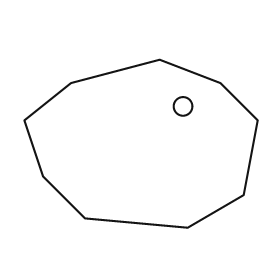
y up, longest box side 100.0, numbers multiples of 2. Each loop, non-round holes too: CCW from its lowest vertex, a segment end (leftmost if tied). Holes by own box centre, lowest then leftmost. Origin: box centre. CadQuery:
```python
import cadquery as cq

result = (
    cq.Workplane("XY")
    .moveTo(20.0, -36.0)
    .lineTo(44.0, -22.0)
    .lineTo(50.0, 10.0)
    .lineTo(34.0, 26.0)
    .lineTo(8.0, 36.0)
    .lineTo(-30.0, 26.0)
    .lineTo(-50.0, 10.0)
    .lineTo(-42.0, -14.0)
    .lineTo(-24.0, -32.0)
    .close()
    .moveTo(18.0, 16.0)
    .circle(4.0)
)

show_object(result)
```